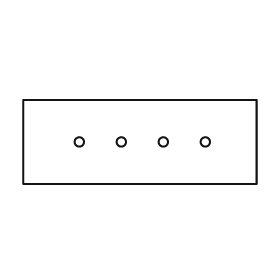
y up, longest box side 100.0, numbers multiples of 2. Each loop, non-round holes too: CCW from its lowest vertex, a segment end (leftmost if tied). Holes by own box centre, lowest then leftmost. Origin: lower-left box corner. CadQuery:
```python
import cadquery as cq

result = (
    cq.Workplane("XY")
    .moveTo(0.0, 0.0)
    .lineTo(100.0, 0.0)
    .lineTo(100.0, 36.0)
    .lineTo(0.0, 36.0)
    .close()
    .moveTo(24.0, 18.0)
    .circle(2.0)
    .moveTo(42.0, 18.0)
    .circle(2.0)
    .moveTo(60.0, 18.0)
    .circle(2.0)
    .moveTo(78.0, 18.0)
    .circle(2.0)
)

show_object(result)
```